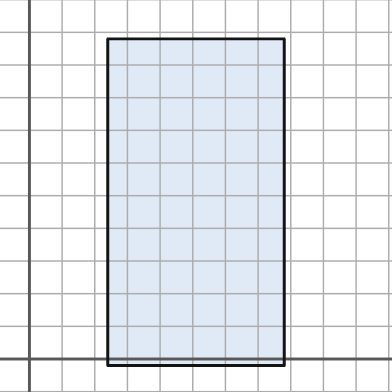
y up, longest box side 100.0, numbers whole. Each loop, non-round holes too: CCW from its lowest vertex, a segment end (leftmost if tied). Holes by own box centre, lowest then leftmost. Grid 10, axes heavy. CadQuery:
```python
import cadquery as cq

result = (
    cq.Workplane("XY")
    .moveTo(24.0, -2.0)
    .lineTo(78.0, -2.0)
    .lineTo(78.0, 98.0)
    .lineTo(24.0, 98.0)
    .close()
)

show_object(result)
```